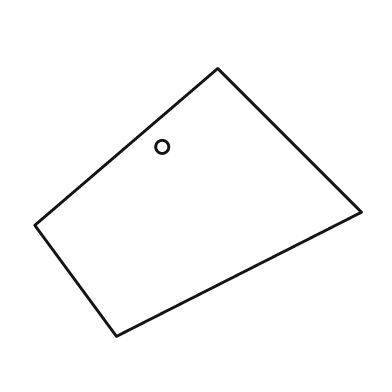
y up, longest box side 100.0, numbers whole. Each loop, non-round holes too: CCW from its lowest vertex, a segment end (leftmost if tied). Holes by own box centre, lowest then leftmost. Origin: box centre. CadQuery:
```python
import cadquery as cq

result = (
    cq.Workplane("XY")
    .moveTo(-25.0, -41.0)
    .lineTo(50.0, -3.0)
    .lineTo(6.0, 41.0)
    .lineTo(-50.0, -7.0)
    .close()
    .moveTo(-11.0, 17.0)
    .circle(2.0)
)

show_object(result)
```